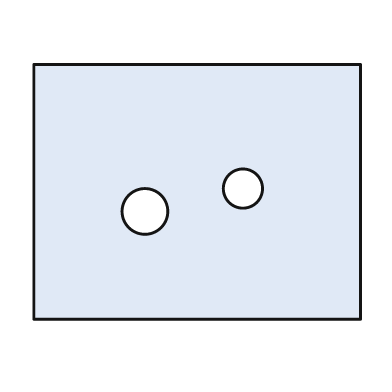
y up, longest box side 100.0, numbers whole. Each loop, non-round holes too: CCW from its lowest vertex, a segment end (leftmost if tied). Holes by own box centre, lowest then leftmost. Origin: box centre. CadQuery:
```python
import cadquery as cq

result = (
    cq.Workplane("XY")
    .moveTo(-50.0, -39.0)
    .lineTo(50.0, -39.0)
    .lineTo(50.0, 39.0)
    .lineTo(-50.0, 39.0)
    .close()
    .moveTo(-16.0, -6.0)
    .circle(7.0)
    .moveTo(14.0, 1.0)
    .circle(6.0)
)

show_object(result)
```